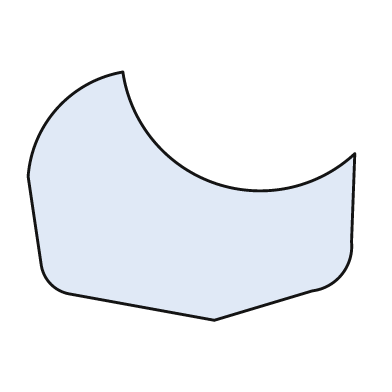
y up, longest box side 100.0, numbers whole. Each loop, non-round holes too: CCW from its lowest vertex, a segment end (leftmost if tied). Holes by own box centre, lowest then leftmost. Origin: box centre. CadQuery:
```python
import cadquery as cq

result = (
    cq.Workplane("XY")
    .moveTo(7.0, -38.0)
    .lineTo(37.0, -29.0)
    .threePointArc((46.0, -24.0), (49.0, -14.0))
    .lineTo(50.0, 13.0)
    .threePointArc((7.0, 4.0), (-21.0, 38.0))
    .threePointArc((-41.0, 27.0), (-50.0, 6.0))
    .lineTo(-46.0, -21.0)
    .threePointArc((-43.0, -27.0), (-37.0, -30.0))
    .close()
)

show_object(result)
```